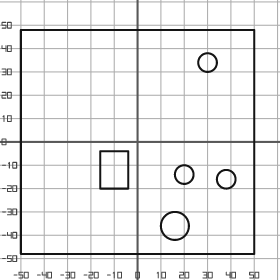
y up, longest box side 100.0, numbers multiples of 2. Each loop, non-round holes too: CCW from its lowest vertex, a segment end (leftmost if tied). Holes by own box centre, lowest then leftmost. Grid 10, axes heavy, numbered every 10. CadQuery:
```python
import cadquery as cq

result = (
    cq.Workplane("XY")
    .moveTo(-50.0, -48.0)
    .lineTo(50.0, -48.0)
    .lineTo(50.0, 48.0)
    .lineTo(-50.0, 48.0)
    .close()
    .moveTo(16.0, -36.0)
    .circle(6.0)
    .moveTo(38.0, -16.0)
    .circle(4.0)
    .moveTo(20.0, -14.0)
    .circle(4.0)
    .moveTo(-16.0, -20.0)
    .lineTo(-4.0, -20.0)
    .lineTo(-4.0, -4.0)
    .lineTo(-16.0, -4.0)
    .close()
    .moveTo(30.0, 34.0)
    .circle(4.0)
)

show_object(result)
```